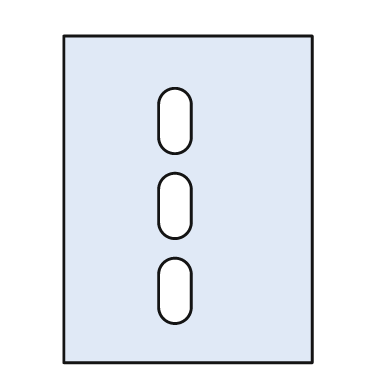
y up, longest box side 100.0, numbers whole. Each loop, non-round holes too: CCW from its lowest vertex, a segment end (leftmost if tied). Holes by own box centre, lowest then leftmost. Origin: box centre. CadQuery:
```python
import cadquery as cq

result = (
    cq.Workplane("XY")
    .moveTo(-38.0, -50.0)
    .lineTo(38.0, -50.0)
    .lineTo(38.0, 50.0)
    .lineTo(-38.0, 50.0)
    .close()
    .moveTo(-9.0, -33.0)
    .threePointArc((-4.0, -38.0), (1.0, -33.0))
    .lineTo(1.0, -23.0)
    .threePointArc((-4.0, -18.0), (-9.0, -23.0))
    .close()
    .moveTo(-9.0, -7.0)
    .threePointArc((-4.0, -12.0), (1.0, -7.0))
    .lineTo(1.0, 3.0)
    .threePointArc((-4.0, 8.0), (-9.0, 3.0))
    .close()
    .moveTo(-9.0, 19.0)
    .threePointArc((-4.0, 14.0), (1.0, 19.0))
    .lineTo(1.0, 29.0)
    .threePointArc((-4.0, 34.0), (-9.0, 29.0))
    .close()
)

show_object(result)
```